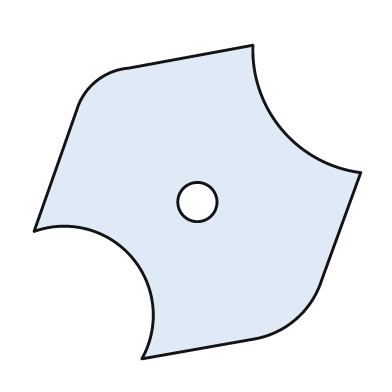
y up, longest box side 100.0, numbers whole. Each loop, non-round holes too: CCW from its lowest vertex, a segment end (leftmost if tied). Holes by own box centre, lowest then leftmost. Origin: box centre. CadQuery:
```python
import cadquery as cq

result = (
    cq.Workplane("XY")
    .moveTo(-17.0, -48.0)
    .lineTo(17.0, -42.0)
    .threePointArc((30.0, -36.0), (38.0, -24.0))
    .lineTo(50.0, 9.0)
    .threePointArc((26.0, 22.0), (17.0, 48.0))
    .lineTo(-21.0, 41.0)
    .threePointArc((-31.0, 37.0), (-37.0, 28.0))
    .lineTo(-50.0, -9.0)
    .threePointArc((-20.0, -17.0), (-17.0, -48.0))
    .close()
    .moveTo(0.0, 0.0)
    .circle(6.0)
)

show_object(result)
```